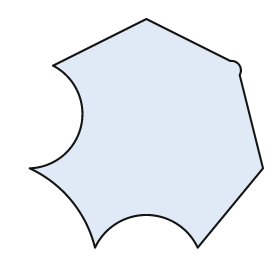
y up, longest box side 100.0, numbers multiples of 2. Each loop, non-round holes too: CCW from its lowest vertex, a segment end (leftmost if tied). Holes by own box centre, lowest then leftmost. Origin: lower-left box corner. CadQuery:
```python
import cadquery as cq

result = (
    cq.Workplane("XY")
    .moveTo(28.0, 0.0)
    .threePointArc((50.0, 14.0), (72.0, 0.0))
    .lineTo(100.0, 34.0)
    .lineTo(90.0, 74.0)
    .threePointArc((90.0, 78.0), (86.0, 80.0))
    .lineTo(50.0, 98.0)
    .lineTo(10.0, 78.0)
    .threePointArc((22.0, 52.0), (0.0, 34.0))
    .threePointArc((18.0, 20.0), (28.0, 0.0))
    .close()
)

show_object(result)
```